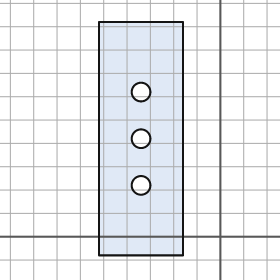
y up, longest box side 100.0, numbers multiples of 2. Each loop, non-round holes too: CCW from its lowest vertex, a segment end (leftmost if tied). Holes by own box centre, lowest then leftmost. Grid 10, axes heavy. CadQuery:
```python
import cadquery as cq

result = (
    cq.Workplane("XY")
    .moveTo(-52.0, -8.0)
    .lineTo(-16.0, -8.0)
    .lineTo(-16.0, 92.0)
    .lineTo(-52.0, 92.0)
    .close()
    .moveTo(-34.0, 22.0)
    .circle(4.0)
    .moveTo(-34.0, 42.0)
    .circle(4.0)
    .moveTo(-34.0, 62.0)
    .circle(4.0)
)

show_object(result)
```